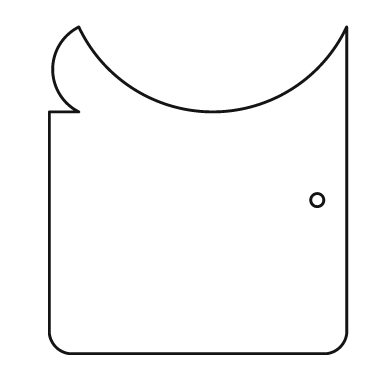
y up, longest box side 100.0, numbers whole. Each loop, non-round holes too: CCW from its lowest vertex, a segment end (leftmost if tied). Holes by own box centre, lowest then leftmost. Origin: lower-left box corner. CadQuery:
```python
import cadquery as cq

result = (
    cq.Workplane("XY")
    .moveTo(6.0, 0.0)
    .lineTo(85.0, 0.0)
    .threePointArc((89.0, 2.0), (91.0, 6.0))
    .lineTo(91.0, 100.0)
    .threePointArc((50.0, 74.0), (9.0, 100.0))
    .threePointArc((1.0, 87.0), (9.0, 74.0))
    .lineTo(0.0, 74.0)
    .lineTo(0.0, 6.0)
    .threePointArc((2.0, 2.0), (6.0, 0.0))
    .close()
    .moveTo(82.0, 47.0)
    .circle(2.0)
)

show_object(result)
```